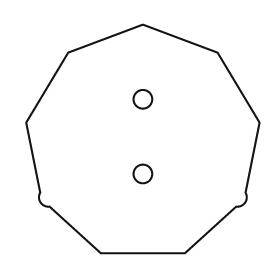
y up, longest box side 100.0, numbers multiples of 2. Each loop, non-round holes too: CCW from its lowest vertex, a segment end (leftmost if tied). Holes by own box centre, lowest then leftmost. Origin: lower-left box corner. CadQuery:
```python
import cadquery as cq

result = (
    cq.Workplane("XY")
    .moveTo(32.0, 0.0)
    .lineTo(68.0, 0.0)
    .lineTo(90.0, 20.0)
    .threePointArc((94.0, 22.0), (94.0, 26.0))
    .lineTo(100.0, 56.0)
    .lineTo(82.0, 86.0)
    .lineTo(50.0, 98.0)
    .lineTo(18.0, 86.0)
    .lineTo(0.0, 56.0)
    .lineTo(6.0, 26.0)
    .threePointArc((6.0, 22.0), (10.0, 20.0))
    .close()
    .moveTo(50.0, 34.0)
    .circle(4.0)
    .moveTo(50.0, 66.0)
    .circle(4.0)
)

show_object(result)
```